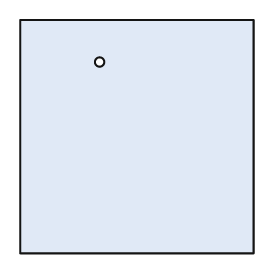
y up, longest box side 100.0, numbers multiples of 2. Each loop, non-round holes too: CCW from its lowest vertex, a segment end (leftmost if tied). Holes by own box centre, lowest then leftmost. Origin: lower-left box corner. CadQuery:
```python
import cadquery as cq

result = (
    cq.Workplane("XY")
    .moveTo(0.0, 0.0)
    .lineTo(100.0, 0.0)
    .lineTo(100.0, 100.0)
    .lineTo(0.0, 100.0)
    .close()
    .moveTo(34.0, 82.0)
    .circle(2.0)
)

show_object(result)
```